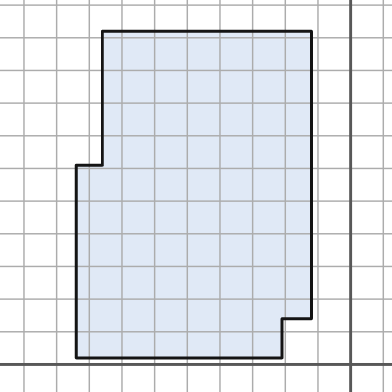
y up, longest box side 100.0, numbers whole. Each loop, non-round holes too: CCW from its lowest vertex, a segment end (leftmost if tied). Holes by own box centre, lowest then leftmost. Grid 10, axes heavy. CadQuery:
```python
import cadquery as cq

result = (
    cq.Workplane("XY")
    .moveTo(-84.0, 2.0)
    .lineTo(-21.0, 2.0)
    .lineTo(-21.0, 14.0)
    .lineTo(-12.0, 14.0)
    .lineTo(-12.0, 102.0)
    .lineTo(-76.0, 102.0)
    .lineTo(-76.0, 61.0)
    .lineTo(-84.0, 61.0)
    .close()
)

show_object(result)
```